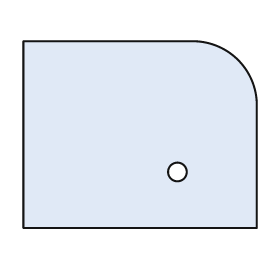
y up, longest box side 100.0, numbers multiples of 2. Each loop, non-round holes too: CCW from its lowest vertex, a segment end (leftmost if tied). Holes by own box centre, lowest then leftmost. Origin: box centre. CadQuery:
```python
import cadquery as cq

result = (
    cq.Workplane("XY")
    .moveTo(-50.0, -40.0)
    .lineTo(50.0, -40.0)
    .lineTo(50.0, 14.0)
    .threePointArc((42.0, 32.0), (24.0, 40.0))
    .lineTo(-50.0, 40.0)
    .close()
    .moveTo(16.0, -16.0)
    .circle(4.0)
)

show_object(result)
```